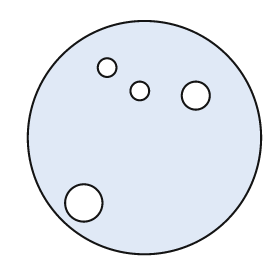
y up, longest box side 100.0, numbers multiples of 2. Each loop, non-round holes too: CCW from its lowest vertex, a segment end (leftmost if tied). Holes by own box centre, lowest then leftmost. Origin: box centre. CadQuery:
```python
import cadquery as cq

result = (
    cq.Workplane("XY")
    .moveTo(0.0, 0.0)
    .circle(50.0)
    .moveTo(-26.0, -28.0)
    .circle(8.0)
    .moveTo(22.0, 18.0)
    .circle(6.0)
    .moveTo(-2.0, 20.0)
    .circle(4.0)
    .moveTo(-16.0, 30.0)
    .circle(4.0)
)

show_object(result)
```